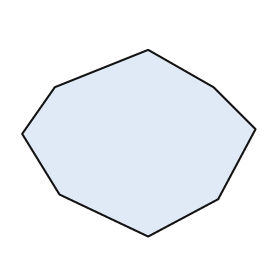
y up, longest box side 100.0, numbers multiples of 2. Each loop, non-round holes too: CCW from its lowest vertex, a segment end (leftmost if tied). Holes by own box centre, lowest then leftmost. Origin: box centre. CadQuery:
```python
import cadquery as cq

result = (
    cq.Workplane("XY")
    .moveTo(4.0, -40.0)
    .lineTo(34.0, -24.0)
    .lineTo(50.0, 6.0)
    .lineTo(32.0, 24.0)
    .lineTo(4.0, 40.0)
    .lineTo(-36.0, 24.0)
    .lineTo(-50.0, 4.0)
    .lineTo(-34.0, -22.0)
    .close()
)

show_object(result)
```